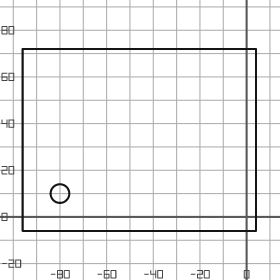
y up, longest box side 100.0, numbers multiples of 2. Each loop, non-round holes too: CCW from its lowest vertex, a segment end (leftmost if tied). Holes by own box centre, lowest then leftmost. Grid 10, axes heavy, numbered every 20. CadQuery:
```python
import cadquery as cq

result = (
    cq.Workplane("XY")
    .moveTo(-96.0, -6.0)
    .lineTo(4.0, -6.0)
    .lineTo(4.0, 72.0)
    .lineTo(-96.0, 72.0)
    .close()
    .moveTo(-80.0, 10.0)
    .circle(4.0)
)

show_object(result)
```